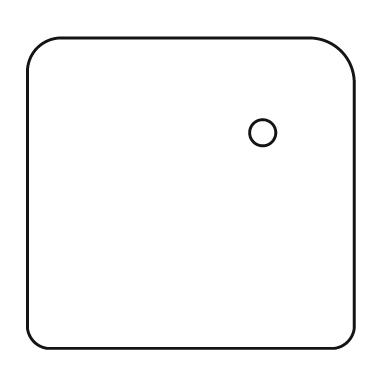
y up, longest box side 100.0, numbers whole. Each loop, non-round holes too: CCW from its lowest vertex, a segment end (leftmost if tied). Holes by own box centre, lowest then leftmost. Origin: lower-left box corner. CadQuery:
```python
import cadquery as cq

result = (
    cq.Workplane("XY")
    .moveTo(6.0, 0.0)
    .lineTo(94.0, 0.0)
    .threePointArc((98.0, 2.0), (100.0, 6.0))
    .lineTo(100.0, 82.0)
    .threePointArc((96.0, 91.0), (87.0, 95.0))
    .lineTo(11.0, 95.0)
    .threePointArc((3.0, 92.0), (0.0, 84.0))
    .lineTo(0.0, 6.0)
    .threePointArc((2.0, 2.0), (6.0, 0.0))
    .close()
    .moveTo(72.0, 66.0)
    .circle(4.0)
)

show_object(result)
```